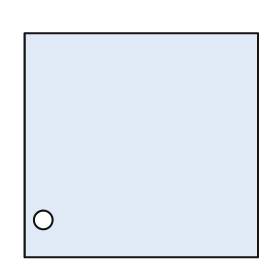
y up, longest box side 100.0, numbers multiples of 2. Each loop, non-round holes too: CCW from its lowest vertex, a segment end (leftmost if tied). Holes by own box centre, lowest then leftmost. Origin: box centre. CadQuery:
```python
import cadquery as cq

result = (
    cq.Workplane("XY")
    .moveTo(-50.0, -48.0)
    .lineTo(50.0, -48.0)
    .lineTo(50.0, 48.0)
    .lineTo(-50.0, 48.0)
    .close()
    .moveTo(-42.0, -32.0)
    .circle(4.0)
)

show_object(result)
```